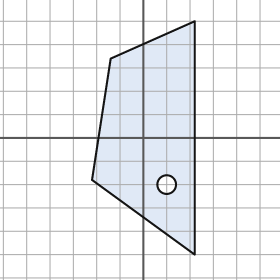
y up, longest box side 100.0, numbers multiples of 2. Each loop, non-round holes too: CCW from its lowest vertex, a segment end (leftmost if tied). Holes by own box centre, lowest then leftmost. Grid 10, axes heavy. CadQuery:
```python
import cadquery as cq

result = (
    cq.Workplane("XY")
    .moveTo(22.0, -50.0)
    .lineTo(22.0, 50.0)
    .lineTo(-14.0, 34.0)
    .lineTo(-22.0, -18.0)
    .close()
    .moveTo(10.0, -20.0)
    .circle(4.0)
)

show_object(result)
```